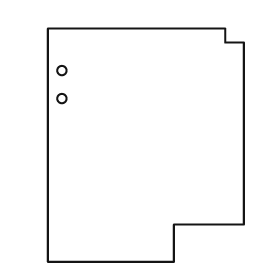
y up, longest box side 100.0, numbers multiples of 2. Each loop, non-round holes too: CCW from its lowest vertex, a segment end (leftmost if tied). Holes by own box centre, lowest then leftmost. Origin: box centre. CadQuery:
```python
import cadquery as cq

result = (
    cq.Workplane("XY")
    .moveTo(-42.0, -50.0)
    .lineTo(12.0, -50.0)
    .lineTo(12.0, -34.0)
    .lineTo(42.0, -34.0)
    .lineTo(42.0, 44.0)
    .lineTo(34.0, 44.0)
    .lineTo(34.0, 50.0)
    .lineTo(-42.0, 50.0)
    .close()
    .moveTo(-36.0, 20.0)
    .circle(2.0)
    .moveTo(-36.0, 32.0)
    .circle(2.0)
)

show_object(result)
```